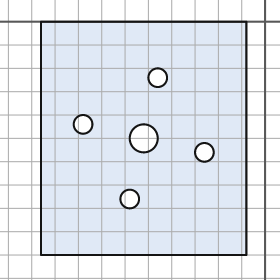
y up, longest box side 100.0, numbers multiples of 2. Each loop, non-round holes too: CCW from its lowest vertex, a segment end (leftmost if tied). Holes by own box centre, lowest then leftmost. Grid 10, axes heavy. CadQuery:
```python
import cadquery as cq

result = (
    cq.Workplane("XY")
    .moveTo(-96.0, -100.0)
    .lineTo(-8.0, -100.0)
    .lineTo(-8.0, 0.0)
    .lineTo(-96.0, 0.0)
    .close()
    .moveTo(-58.0, -76.0)
    .circle(4.0)
    .moveTo(-26.0, -56.0)
    .circle(4.0)
    .moveTo(-52.0, -50.0)
    .circle(6.0)
    .moveTo(-78.0, -44.0)
    .circle(4.0)
    .moveTo(-46.0, -24.0)
    .circle(4.0)
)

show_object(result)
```